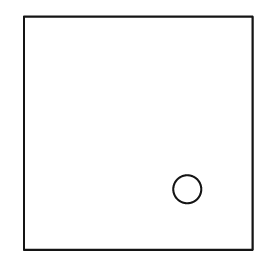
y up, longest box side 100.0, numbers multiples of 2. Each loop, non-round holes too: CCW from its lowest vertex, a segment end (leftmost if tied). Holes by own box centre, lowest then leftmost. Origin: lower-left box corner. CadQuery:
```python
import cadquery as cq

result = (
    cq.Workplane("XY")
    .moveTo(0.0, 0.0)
    .lineTo(98.0, 0.0)
    .lineTo(98.0, 100.0)
    .lineTo(0.0, 100.0)
    .close()
    .moveTo(70.0, 26.0)
    .circle(6.0)
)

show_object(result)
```